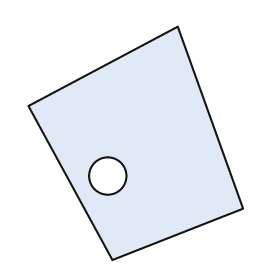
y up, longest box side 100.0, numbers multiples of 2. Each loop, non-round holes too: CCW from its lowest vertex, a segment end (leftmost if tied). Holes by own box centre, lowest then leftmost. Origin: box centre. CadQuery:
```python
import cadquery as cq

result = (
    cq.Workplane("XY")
    .moveTo(-10.0, -50.0)
    .lineTo(46.0, -28.0)
    .lineTo(18.0, 50.0)
    .lineTo(-46.0, 16.0)
    .close()
    .moveTo(-12.0, -14.0)
    .circle(8.0)
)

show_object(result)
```